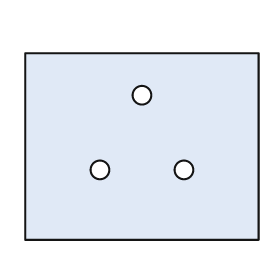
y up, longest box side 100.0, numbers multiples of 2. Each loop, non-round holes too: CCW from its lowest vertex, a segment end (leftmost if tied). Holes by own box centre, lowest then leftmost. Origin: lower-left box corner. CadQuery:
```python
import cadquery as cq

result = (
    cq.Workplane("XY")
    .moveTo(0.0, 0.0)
    .lineTo(100.0, 0.0)
    .lineTo(100.0, 80.0)
    .lineTo(0.0, 80.0)
    .close()
    .moveTo(32.0, 30.0)
    .circle(4.0)
    .moveTo(68.0, 30.0)
    .circle(4.0)
    .moveTo(50.0, 62.0)
    .circle(4.0)
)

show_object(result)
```